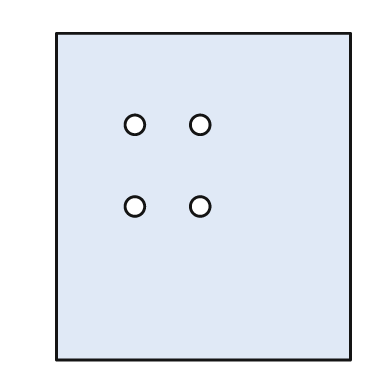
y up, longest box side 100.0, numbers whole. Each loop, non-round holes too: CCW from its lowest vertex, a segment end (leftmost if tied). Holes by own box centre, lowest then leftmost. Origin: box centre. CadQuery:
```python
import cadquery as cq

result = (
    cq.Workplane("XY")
    .moveTo(-45.0, -50.0)
    .lineTo(45.0, -50.0)
    .lineTo(45.0, 50.0)
    .lineTo(-45.0, 50.0)
    .close()
    .moveTo(-21.0, -3.0)
    .circle(3.0)
    .moveTo(-1.0, -3.0)
    .circle(3.0)
    .moveTo(-21.0, 22.0)
    .circle(3.0)
    .moveTo(-1.0, 22.0)
    .circle(3.0)
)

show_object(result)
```